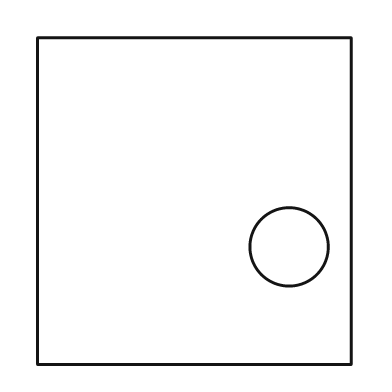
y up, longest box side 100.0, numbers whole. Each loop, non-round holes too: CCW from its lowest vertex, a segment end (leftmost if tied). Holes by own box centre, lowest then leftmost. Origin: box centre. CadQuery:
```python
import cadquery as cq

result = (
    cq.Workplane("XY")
    .moveTo(-48.0, -50.0)
    .lineTo(48.0, -50.0)
    .lineTo(48.0, 50.0)
    .lineTo(-48.0, 50.0)
    .close()
    .moveTo(29.0, -14.0)
    .circle(12.0)
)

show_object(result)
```